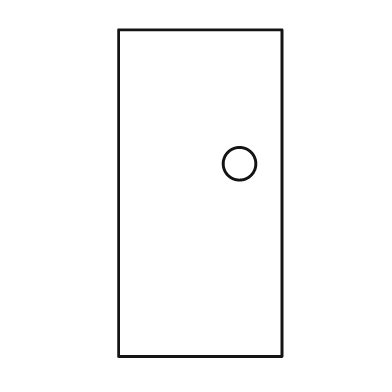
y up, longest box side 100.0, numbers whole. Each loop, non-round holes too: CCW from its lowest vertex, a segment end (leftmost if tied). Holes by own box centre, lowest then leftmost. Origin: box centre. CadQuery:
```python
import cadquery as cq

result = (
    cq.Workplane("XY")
    .moveTo(-25.0, -50.0)
    .lineTo(25.0, -50.0)
    .lineTo(25.0, 50.0)
    .lineTo(-25.0, 50.0)
    .close()
    .moveTo(12.0, 9.0)
    .circle(5.0)
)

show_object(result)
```